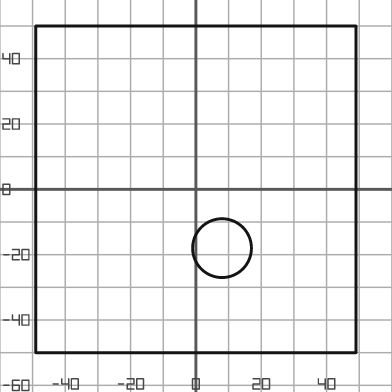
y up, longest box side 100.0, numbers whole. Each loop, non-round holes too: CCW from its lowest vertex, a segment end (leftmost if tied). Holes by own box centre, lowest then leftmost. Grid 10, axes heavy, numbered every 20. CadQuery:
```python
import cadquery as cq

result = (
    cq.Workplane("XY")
    .moveTo(-49.0, -50.0)
    .lineTo(49.0, -50.0)
    .lineTo(49.0, 50.0)
    .lineTo(-49.0, 50.0)
    .close()
    .moveTo(8.0, -18.0)
    .circle(9.0)
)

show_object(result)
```